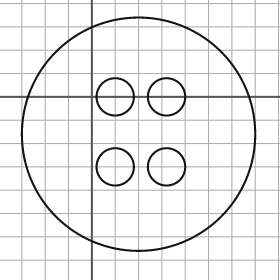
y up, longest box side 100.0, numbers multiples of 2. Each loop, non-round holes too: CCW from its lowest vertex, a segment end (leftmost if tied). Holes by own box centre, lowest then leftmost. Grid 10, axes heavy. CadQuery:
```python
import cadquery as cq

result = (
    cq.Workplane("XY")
    .moveTo(20.0, -16.0)
    .circle(50.0)
    .moveTo(10.0, -30.0)
    .circle(8.0)
    .moveTo(32.0, -30.0)
    .circle(8.0)
    .moveTo(10.0, 0.0)
    .circle(8.0)
    .moveTo(32.0, 0.0)
    .circle(8.0)
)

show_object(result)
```